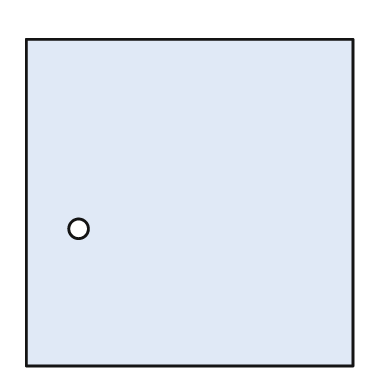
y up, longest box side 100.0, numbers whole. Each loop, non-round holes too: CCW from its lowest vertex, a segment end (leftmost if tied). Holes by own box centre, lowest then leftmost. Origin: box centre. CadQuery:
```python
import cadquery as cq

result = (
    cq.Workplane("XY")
    .moveTo(-50.0, -50.0)
    .lineTo(50.0, -50.0)
    .lineTo(50.0, 50.0)
    .lineTo(-50.0, 50.0)
    .close()
    .moveTo(-34.0, -8.0)
    .circle(3.0)
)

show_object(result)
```